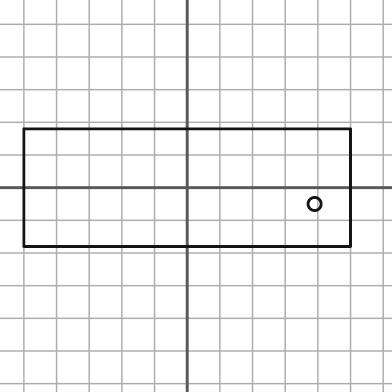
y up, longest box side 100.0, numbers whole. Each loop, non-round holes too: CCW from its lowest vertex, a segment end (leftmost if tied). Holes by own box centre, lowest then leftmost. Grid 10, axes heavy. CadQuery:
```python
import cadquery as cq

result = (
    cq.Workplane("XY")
    .moveTo(-50.0, -18.0)
    .lineTo(50.0, -18.0)
    .lineTo(50.0, 18.0)
    .lineTo(-50.0, 18.0)
    .close()
    .moveTo(39.0, -5.0)
    .circle(2.0)
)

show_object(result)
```